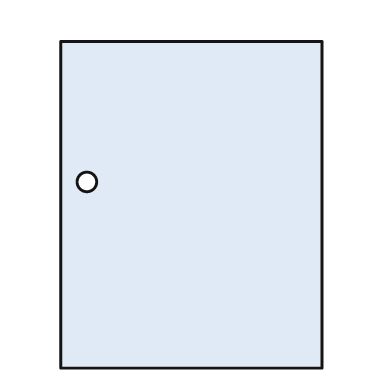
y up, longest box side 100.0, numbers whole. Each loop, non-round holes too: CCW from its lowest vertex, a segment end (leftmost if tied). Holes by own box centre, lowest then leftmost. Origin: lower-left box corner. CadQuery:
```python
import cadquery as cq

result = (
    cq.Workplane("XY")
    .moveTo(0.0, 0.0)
    .lineTo(80.0, 0.0)
    .lineTo(80.0, 100.0)
    .lineTo(0.0, 100.0)
    .close()
    .moveTo(8.0, 57.0)
    .circle(3.0)
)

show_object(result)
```